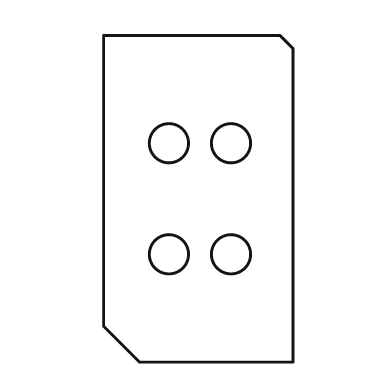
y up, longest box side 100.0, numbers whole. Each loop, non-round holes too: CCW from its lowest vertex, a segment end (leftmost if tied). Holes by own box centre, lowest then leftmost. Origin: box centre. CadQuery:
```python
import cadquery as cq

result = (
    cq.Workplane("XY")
    .moveTo(-18.0, -50.0)
    .lineTo(29.0, -50.0)
    .lineTo(29.0, 46.0)
    .lineTo(25.0, 50.0)
    .lineTo(-29.0, 50.0)
    .lineTo(-29.0, -39.0)
    .close()
    .moveTo(-9.0, -17.0)
    .circle(6.0)
    .moveTo(10.0, -17.0)
    .circle(6.0)
    .moveTo(-9.0, 17.0)
    .circle(6.0)
    .moveTo(10.0, 17.0)
    .circle(6.0)
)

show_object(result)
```